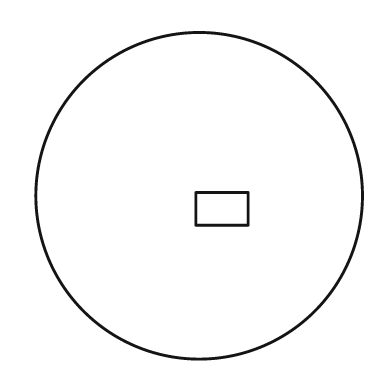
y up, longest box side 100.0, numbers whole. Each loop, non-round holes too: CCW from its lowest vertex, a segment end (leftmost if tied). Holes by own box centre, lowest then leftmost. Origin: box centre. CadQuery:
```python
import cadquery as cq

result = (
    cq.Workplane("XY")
    .moveTo(0.0, 0.0)
    .circle(50.0)
    .moveTo(-1.0, -9.0)
    .lineTo(15.0, -9.0)
    .lineTo(15.0, 1.0)
    .lineTo(-1.0, 1.0)
    .close()
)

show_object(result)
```